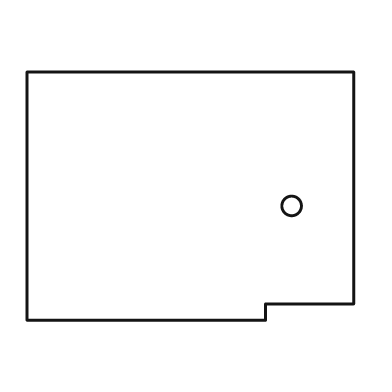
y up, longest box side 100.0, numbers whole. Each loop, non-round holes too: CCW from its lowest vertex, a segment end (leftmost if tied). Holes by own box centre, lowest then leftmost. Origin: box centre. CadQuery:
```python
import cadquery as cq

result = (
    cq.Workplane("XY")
    .moveTo(-50.0, -38.0)
    .lineTo(23.0, -38.0)
    .lineTo(23.0, -33.0)
    .lineTo(50.0, -33.0)
    .lineTo(50.0, 38.0)
    .lineTo(-50.0, 38.0)
    .close()
    .moveTo(31.0, -3.0)
    .circle(3.0)
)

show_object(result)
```